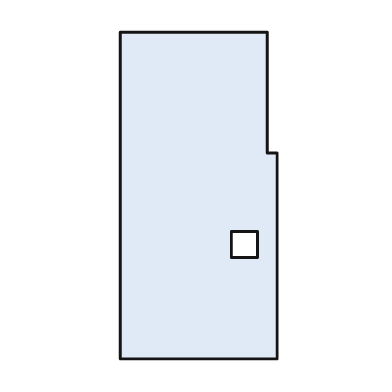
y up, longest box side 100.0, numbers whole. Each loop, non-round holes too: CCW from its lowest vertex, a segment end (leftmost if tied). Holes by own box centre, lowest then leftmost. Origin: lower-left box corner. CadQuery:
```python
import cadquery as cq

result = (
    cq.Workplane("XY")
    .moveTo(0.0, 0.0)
    .lineTo(48.0, 0.0)
    .lineTo(48.0, 63.0)
    .lineTo(45.0, 63.0)
    .lineTo(45.0, 100.0)
    .lineTo(0.0, 100.0)
    .close()
    .moveTo(34.0, 31.0)
    .lineTo(42.0, 31.0)
    .lineTo(42.0, 39.0)
    .lineTo(34.0, 39.0)
    .close()
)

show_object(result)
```